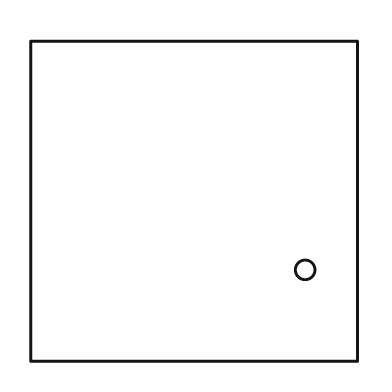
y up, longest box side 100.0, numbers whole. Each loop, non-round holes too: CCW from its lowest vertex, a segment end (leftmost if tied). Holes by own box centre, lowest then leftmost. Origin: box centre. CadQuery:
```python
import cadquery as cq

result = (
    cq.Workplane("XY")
    .moveTo(-50.0, -49.0)
    .lineTo(50.0, -49.0)
    .lineTo(50.0, 49.0)
    .lineTo(-50.0, 49.0)
    .close()
    .moveTo(34.0, -21.0)
    .circle(3.0)
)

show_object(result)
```